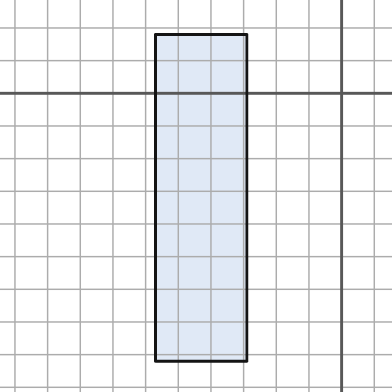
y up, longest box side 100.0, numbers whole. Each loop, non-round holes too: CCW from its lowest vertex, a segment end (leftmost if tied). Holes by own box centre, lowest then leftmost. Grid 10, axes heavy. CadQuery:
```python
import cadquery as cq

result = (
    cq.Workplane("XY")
    .moveTo(-57.0, -82.0)
    .lineTo(-29.0, -82.0)
    .lineTo(-29.0, 18.0)
    .lineTo(-57.0, 18.0)
    .close()
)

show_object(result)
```